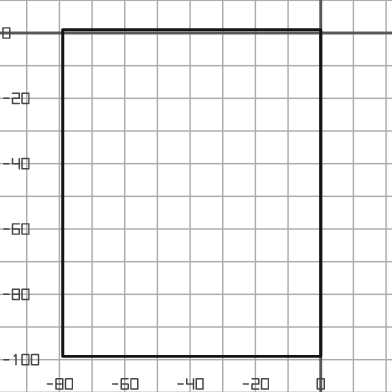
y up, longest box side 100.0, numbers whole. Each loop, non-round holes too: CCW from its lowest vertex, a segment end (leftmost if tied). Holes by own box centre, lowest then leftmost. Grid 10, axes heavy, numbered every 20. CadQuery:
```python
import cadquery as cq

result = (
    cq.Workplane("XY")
    .moveTo(-79.0, -99.0)
    .lineTo(0.0, -99.0)
    .lineTo(0.0, 1.0)
    .lineTo(-79.0, 1.0)
    .close()
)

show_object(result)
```